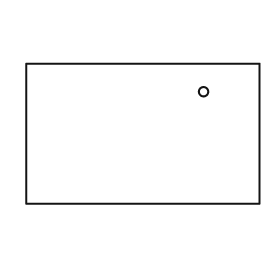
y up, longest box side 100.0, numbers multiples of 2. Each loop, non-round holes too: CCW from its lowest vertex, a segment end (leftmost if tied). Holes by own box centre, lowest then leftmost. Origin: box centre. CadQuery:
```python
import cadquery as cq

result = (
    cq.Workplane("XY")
    .moveTo(-50.0, -30.0)
    .lineTo(50.0, -30.0)
    .lineTo(50.0, 30.0)
    .lineTo(-50.0, 30.0)
    .close()
    .moveTo(26.0, 18.0)
    .circle(2.0)
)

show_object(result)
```